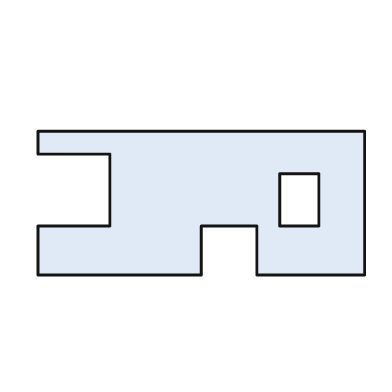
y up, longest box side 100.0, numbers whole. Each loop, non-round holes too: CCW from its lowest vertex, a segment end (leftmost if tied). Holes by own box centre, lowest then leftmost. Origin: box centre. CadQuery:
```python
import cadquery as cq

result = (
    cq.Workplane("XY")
    .moveTo(-50.0, -22.0)
    .lineTo(0.0, -22.0)
    .lineTo(0.0, -7.0)
    .lineTo(17.0, -7.0)
    .lineTo(17.0, -22.0)
    .lineTo(50.0, -22.0)
    .lineTo(50.0, 22.0)
    .lineTo(-50.0, 22.0)
    .lineTo(-50.0, 15.0)
    .lineTo(-28.0, 15.0)
    .lineTo(-28.0, -7.0)
    .lineTo(-50.0, -7.0)
    .close()
    .moveTo(24.0, -7.0)
    .lineTo(36.0, -7.0)
    .lineTo(36.0, 9.0)
    .lineTo(24.0, 9.0)
    .close()
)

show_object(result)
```